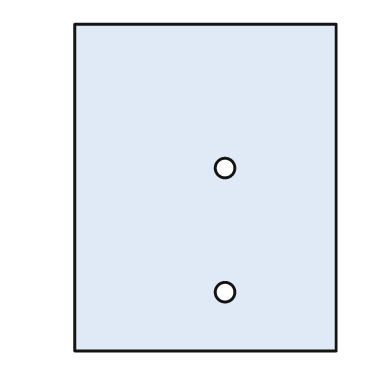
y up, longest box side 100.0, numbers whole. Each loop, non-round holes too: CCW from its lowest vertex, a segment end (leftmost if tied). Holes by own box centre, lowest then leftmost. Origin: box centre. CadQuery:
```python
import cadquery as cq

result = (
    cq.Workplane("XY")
    .moveTo(-40.0, -50.0)
    .lineTo(40.0, -50.0)
    .lineTo(40.0, 50.0)
    .lineTo(-40.0, 50.0)
    .close()
    .moveTo(6.0, -32.0)
    .circle(3.0)
    .moveTo(6.0, 6.0)
    .circle(3.0)
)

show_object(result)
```